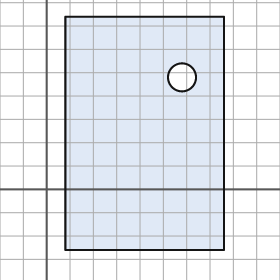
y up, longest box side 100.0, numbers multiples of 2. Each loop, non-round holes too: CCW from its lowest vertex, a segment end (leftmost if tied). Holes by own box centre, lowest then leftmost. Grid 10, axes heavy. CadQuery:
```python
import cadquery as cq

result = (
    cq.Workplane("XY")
    .moveTo(8.0, -26.0)
    .lineTo(76.0, -26.0)
    .lineTo(76.0, 74.0)
    .lineTo(8.0, 74.0)
    .close()
    .moveTo(58.0, 48.0)
    .circle(6.0)
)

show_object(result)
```